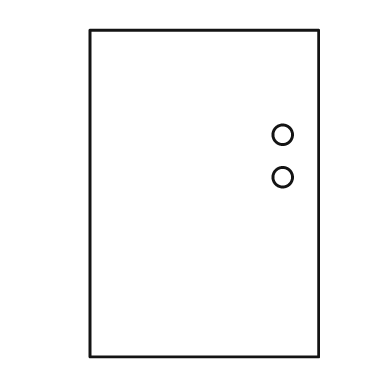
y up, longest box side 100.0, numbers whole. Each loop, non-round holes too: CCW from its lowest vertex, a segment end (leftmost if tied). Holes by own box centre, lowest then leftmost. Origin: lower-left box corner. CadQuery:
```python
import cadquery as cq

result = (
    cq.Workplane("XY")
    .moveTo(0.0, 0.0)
    .lineTo(70.0, 0.0)
    .lineTo(70.0, 100.0)
    .lineTo(0.0, 100.0)
    .close()
    .moveTo(59.0, 55.0)
    .circle(3.0)
    .moveTo(59.0, 68.0)
    .circle(3.0)
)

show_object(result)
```